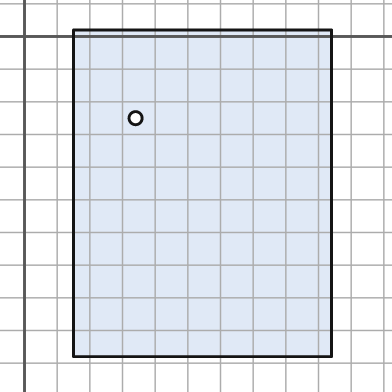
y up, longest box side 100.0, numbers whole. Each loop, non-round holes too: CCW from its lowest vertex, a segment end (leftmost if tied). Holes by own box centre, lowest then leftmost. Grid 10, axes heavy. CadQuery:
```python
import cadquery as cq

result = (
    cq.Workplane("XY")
    .moveTo(15.0, -98.0)
    .lineTo(94.0, -98.0)
    .lineTo(94.0, 2.0)
    .lineTo(15.0, 2.0)
    .close()
    .moveTo(34.0, -25.0)
    .circle(2.0)
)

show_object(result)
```